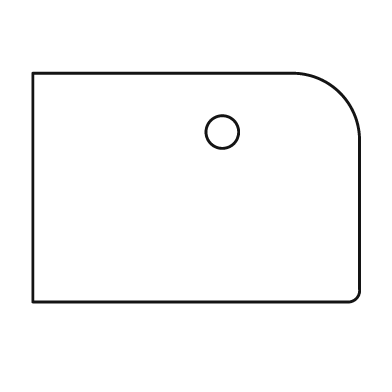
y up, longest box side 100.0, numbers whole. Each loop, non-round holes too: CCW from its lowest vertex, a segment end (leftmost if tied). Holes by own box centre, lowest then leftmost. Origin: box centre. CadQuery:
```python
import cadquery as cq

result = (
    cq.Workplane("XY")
    .moveTo(-50.0, -35.0)
    .lineTo(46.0, -35.0)
    .threePointArc((49.0, -34.0), (50.0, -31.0))
    .lineTo(50.0, 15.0)
    .threePointArc((44.0, 29.0), (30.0, 35.0))
    .lineTo(-50.0, 35.0)
    .close()
    .moveTo(8.0, 17.0)
    .circle(5.0)
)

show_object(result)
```